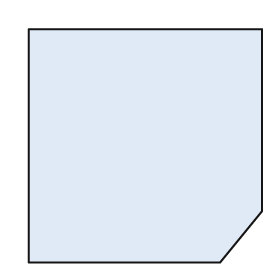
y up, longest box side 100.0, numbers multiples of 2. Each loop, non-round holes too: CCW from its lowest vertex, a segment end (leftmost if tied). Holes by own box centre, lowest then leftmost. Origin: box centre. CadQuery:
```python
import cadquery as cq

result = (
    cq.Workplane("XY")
    .moveTo(-50.0, -50.0)
    .lineTo(32.0, -50.0)
    .lineTo(50.0, -28.0)
    .lineTo(50.0, 50.0)
    .lineTo(-50.0, 50.0)
    .close()
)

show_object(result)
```